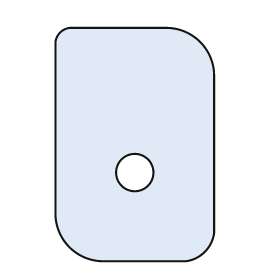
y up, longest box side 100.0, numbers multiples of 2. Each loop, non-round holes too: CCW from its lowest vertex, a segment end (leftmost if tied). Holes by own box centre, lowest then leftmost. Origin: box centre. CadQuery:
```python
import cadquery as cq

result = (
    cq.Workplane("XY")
    .moveTo(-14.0, -50.0)
    .lineTo(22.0, -50.0)
    .threePointArc((30.0, -46.0), (34.0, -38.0))
    .lineTo(34.0, 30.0)
    .threePointArc((28.0, 44.0), (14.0, 50.0))
    .lineTo(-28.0, 50.0)
    .threePointArc((-32.0, 48.0), (-34.0, 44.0))
    .lineTo(-34.0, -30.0)
    .threePointArc((-28.0, -44.0), (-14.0, -50.0))
    .close()
    .moveTo(0.0, -12.0)
    .circle(8.0)
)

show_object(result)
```